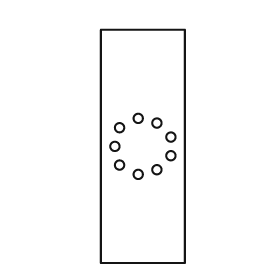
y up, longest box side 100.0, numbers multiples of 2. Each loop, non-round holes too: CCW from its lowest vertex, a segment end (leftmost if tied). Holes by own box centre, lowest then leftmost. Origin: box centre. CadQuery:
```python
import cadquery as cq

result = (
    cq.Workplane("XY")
    .moveTo(-18.0, -50.0)
    .lineTo(18.0, -50.0)
    .lineTo(18.0, 50.0)
    .lineTo(-18.0, 50.0)
    .close()
    .moveTo(-2.0, -12.0)
    .circle(2.0)
    .moveTo(6.0, -10.0)
    .circle(2.0)
    .moveTo(-10.0, -8.0)
    .circle(2.0)
    .moveTo(12.0, -4.0)
    .circle(2.0)
    .moveTo(-12.0, 0.0)
    .circle(2.0)
    .moveTo(12.0, 4.0)
    .circle(2.0)
    .moveTo(-10.0, 8.0)
    .circle(2.0)
    .moveTo(6.0, 10.0)
    .circle(2.0)
    .moveTo(-2.0, 12.0)
    .circle(2.0)
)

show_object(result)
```